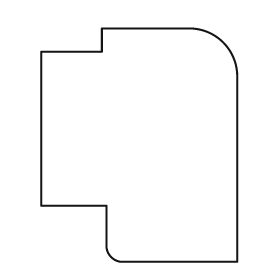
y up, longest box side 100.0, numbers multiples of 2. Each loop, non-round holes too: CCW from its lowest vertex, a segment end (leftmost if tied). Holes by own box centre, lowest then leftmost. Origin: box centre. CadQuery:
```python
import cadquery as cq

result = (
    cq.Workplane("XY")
    .moveTo(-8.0, -50.0)
    .lineTo(42.0, -50.0)
    .lineTo(42.0, 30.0)
    .threePointArc((36.0, 44.0), (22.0, 50.0))
    .lineTo(-16.0, 50.0)
    .lineTo(-16.0, 40.0)
    .lineTo(-42.0, 40.0)
    .lineTo(-42.0, -26.0)
    .lineTo(-14.0, -26.0)
    .lineTo(-14.0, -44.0)
    .threePointArc((-12.0, -48.0), (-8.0, -50.0))
    .close()
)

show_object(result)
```